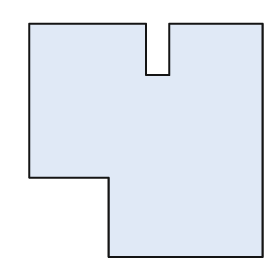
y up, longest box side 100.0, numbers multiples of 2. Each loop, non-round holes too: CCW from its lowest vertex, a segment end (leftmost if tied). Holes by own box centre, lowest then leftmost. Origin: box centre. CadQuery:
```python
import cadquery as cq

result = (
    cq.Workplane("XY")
    .moveTo(-16.0, -50.0)
    .lineTo(50.0, -50.0)
    .lineTo(50.0, 50.0)
    .lineTo(10.0, 50.0)
    .lineTo(10.0, 28.0)
    .lineTo(0.0, 28.0)
    .lineTo(0.0, 50.0)
    .lineTo(-50.0, 50.0)
    .lineTo(-50.0, -16.0)
    .lineTo(-16.0, -16.0)
    .close()
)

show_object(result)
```